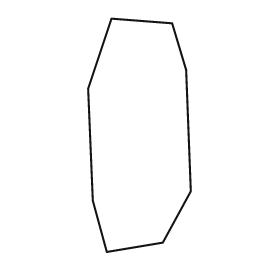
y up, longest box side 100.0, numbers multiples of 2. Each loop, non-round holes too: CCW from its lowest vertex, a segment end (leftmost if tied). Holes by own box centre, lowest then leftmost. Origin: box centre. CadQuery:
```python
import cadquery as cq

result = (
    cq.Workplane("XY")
    .moveTo(-14.0, -50.0)
    .lineTo(10.0, -46.0)
    .lineTo(22.0, -24.0)
    .lineTo(20.0, 28.0)
    .lineTo(14.0, 48.0)
    .lineTo(-12.0, 50.0)
    .lineTo(-22.0, 20.0)
    .lineTo(-20.0, -28.0)
    .close()
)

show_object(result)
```